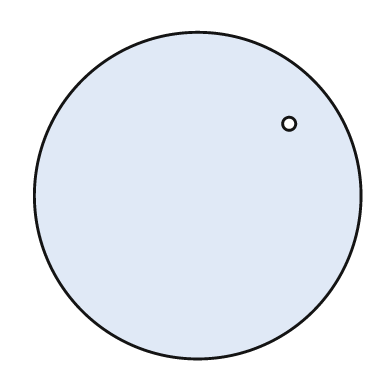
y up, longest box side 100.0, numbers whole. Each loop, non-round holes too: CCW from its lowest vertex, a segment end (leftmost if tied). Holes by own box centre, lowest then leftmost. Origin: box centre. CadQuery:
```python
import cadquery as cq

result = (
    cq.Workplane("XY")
    .moveTo(0.0, 0.0)
    .circle(50.0)
    .moveTo(28.0, 22.0)
    .circle(2.0)
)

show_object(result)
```